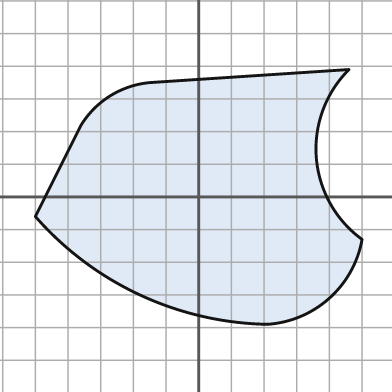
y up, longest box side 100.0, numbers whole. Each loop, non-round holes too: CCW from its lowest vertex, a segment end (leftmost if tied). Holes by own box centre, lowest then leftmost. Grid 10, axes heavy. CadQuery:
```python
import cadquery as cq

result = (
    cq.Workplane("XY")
    .moveTo(21.0, -39.0)
    .threePointArc((40.0, -31.0), (50.0, -13.0))
    .threePointArc((36.0, 12.0), (46.0, 39.0))
    .lineTo(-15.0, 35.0)
    .threePointArc((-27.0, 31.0), (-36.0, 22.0))
    .lineTo(-50.0, -6.0)
    .threePointArc((-18.0, -30.0), (21.0, -39.0))
    .close()
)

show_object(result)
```